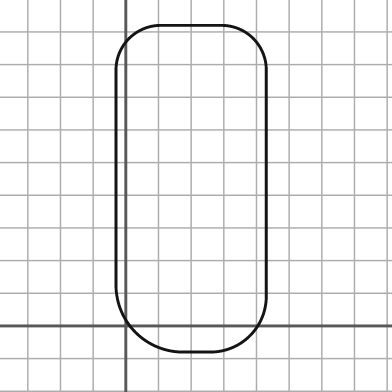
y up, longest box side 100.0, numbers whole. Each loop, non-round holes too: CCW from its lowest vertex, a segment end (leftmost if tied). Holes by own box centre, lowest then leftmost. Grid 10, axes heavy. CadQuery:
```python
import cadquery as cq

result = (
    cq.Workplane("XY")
    .moveTo(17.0, -8.0)
    .lineTo(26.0, -8.0)
    .threePointArc((38.0, -3.0), (43.0, 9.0))
    .lineTo(43.0, 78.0)
    .threePointArc((39.0, 88.0), (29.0, 92.0))
    .lineTo(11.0, 92.0)
    .threePointArc((1.0, 88.0), (-3.0, 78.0))
    .lineTo(-3.0, 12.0)
    .threePointArc((3.0, -2.0), (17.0, -8.0))
    .close()
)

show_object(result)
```